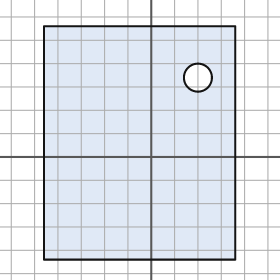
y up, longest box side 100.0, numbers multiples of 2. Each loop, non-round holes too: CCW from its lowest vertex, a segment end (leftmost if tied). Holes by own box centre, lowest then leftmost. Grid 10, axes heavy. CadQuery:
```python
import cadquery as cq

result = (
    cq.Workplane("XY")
    .moveTo(-46.0, -44.0)
    .lineTo(36.0, -44.0)
    .lineTo(36.0, 56.0)
    .lineTo(-46.0, 56.0)
    .close()
    .moveTo(20.0, 34.0)
    .circle(6.0)
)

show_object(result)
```